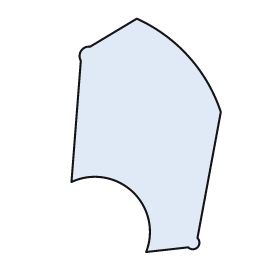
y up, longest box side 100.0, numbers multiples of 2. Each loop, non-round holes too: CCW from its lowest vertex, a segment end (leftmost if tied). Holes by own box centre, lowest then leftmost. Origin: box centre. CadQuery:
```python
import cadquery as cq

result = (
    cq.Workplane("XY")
    .moveTo(0.0, -50.0)
    .lineTo(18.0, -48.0)
    .threePointArc((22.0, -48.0), (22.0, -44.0))
    .lineTo(32.0, 10.0)
    .threePointArc((18.0, 34.0), (-4.0, 50.0))
    .lineTo(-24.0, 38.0)
    .threePointArc((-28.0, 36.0), (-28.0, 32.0))
    .lineTo(-32.0, -20.0)
    .threePointArc((-6.0, -24.0), (0.0, -50.0))
    .close()
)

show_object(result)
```